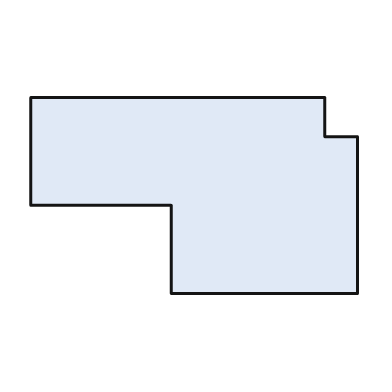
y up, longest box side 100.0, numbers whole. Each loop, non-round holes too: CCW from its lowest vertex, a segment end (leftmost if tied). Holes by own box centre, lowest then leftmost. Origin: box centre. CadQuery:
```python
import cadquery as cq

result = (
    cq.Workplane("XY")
    .moveTo(-7.0, -30.0)
    .lineTo(50.0, -30.0)
    .lineTo(50.0, 18.0)
    .lineTo(40.0, 18.0)
    .lineTo(40.0, 30.0)
    .lineTo(-50.0, 30.0)
    .lineTo(-50.0, -3.0)
    .lineTo(-7.0, -3.0)
    .close()
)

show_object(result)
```